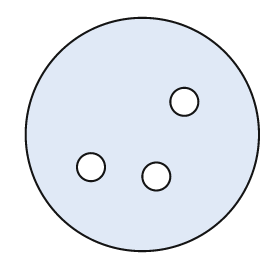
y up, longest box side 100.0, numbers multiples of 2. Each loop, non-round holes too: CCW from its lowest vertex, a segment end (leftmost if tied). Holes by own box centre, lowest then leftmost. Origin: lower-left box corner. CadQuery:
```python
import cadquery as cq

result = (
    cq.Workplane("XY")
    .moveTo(50.0, 50.0)
    .circle(50.0)
    .moveTo(56.0, 32.0)
    .circle(6.0)
    .moveTo(28.0, 36.0)
    .circle(6.0)
    .moveTo(68.0, 64.0)
    .circle(6.0)
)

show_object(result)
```